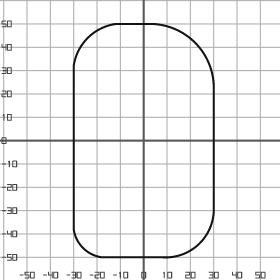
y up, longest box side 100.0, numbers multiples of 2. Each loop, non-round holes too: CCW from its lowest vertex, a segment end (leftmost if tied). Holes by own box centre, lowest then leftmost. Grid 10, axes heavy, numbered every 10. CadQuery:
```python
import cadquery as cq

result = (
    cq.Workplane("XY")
    .moveTo(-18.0, -50.0)
    .lineTo(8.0, -50.0)
    .threePointArc((24.0, -44.0), (30.0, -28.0))
    .lineTo(30.0, 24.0)
    .threePointArc((22.0, 42.0), (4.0, 50.0))
    .lineTo(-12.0, 50.0)
    .threePointArc((-24.0, 44.0), (-30.0, 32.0))
    .lineTo(-30.0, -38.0)
    .threePointArc((-26.0, -46.0), (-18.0, -50.0))
    .close()
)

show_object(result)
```